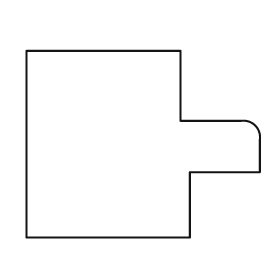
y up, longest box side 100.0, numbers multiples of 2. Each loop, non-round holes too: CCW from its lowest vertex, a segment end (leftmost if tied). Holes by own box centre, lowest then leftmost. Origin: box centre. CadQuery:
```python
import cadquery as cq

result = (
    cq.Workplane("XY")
    .moveTo(-50.0, -40.0)
    .lineTo(20.0, -40.0)
    .lineTo(20.0, -12.0)
    .lineTo(50.0, -12.0)
    .lineTo(50.0, 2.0)
    .threePointArc((48.0, 8.0), (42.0, 10.0))
    .lineTo(16.0, 10.0)
    .lineTo(16.0, 40.0)
    .lineTo(-50.0, 40.0)
    .close()
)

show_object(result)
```